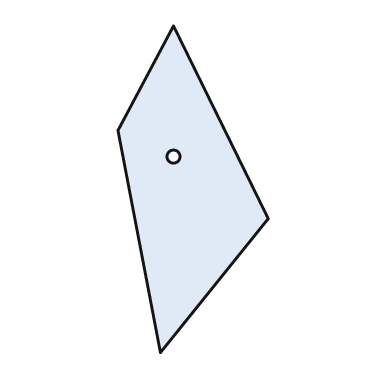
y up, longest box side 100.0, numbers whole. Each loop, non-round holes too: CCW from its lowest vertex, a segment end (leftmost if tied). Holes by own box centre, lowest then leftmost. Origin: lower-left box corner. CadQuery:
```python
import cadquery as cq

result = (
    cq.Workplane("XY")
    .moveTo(13.0, 0.0)
    .lineTo(46.0, 41.0)
    .lineTo(17.0, 100.0)
    .lineTo(0.0, 68.0)
    .close()
    .moveTo(17.0, 60.0)
    .circle(2.0)
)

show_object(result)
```